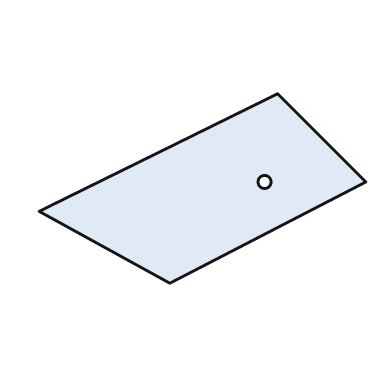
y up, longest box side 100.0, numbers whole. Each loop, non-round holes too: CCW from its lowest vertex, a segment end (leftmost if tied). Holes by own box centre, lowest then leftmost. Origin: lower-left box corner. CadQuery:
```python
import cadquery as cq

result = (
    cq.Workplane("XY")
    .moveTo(40.0, 0.0)
    .lineTo(100.0, 31.0)
    .lineTo(73.0, 58.0)
    .lineTo(0.0, 22.0)
    .close()
    .moveTo(69.0, 31.0)
    .circle(2.0)
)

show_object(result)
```